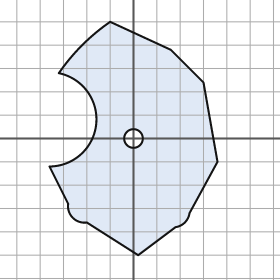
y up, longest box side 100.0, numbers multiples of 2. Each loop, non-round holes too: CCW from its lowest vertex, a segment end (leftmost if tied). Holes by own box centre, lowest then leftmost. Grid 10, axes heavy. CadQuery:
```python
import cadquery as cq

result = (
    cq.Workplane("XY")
    .moveTo(2.0, -50.0)
    .lineTo(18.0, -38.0)
    .threePointArc((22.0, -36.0), (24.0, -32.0))
    .lineTo(36.0, -10.0)
    .lineTo(30.0, 24.0)
    .lineTo(16.0, 38.0)
    .lineTo(-10.0, 50.0)
    .threePointArc((-22.0, 40.0), (-32.0, 28.0))
    .threePointArc((-16.0, 6.0), (-36.0, -12.0))
    .lineTo(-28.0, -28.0)
    .threePointArc((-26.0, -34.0), (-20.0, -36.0))
    .close()
    .moveTo(0.0, 0.0)
    .circle(4.0)
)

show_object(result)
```